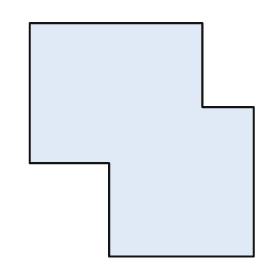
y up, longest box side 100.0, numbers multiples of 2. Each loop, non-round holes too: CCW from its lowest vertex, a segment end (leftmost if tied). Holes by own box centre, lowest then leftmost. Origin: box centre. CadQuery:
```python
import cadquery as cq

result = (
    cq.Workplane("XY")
    .moveTo(-14.0, -50.0)
    .lineTo(48.0, -50.0)
    .lineTo(48.0, 14.0)
    .lineTo(26.0, 14.0)
    .lineTo(26.0, 50.0)
    .lineTo(-48.0, 50.0)
    .lineTo(-48.0, -10.0)
    .lineTo(-14.0, -10.0)
    .close()
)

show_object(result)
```